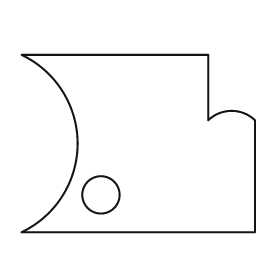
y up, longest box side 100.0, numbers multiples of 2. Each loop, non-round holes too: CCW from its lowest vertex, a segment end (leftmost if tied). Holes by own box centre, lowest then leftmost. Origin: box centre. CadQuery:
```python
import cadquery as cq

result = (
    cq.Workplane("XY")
    .moveTo(-50.0, -38.0)
    .lineTo(50.0, -38.0)
    .lineTo(50.0, 10.0)
    .threePointArc((40.0, 14.0), (30.0, 10.0))
    .lineTo(30.0, 38.0)
    .lineTo(-50.0, 38.0)
    .threePointArc((-26.0, 0.0), (-50.0, -38.0))
    .close()
    .moveTo(-16.0, -22.0)
    .circle(8.0)
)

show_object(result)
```